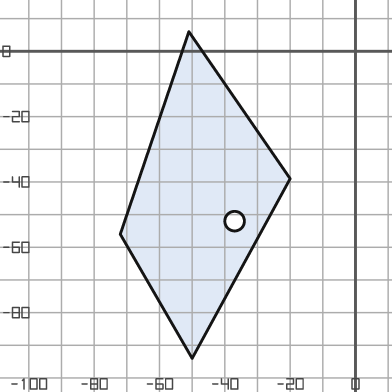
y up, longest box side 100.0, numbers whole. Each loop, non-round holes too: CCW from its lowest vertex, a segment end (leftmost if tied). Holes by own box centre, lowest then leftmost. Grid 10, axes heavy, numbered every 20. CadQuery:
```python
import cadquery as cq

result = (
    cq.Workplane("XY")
    .moveTo(-50.0, -94.0)
    .lineTo(-20.0, -39.0)
    .lineTo(-51.0, 6.0)
    .lineTo(-72.0, -56.0)
    .close()
    .moveTo(-37.0, -52.0)
    .circle(3.0)
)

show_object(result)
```